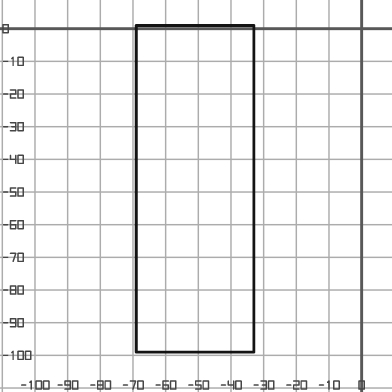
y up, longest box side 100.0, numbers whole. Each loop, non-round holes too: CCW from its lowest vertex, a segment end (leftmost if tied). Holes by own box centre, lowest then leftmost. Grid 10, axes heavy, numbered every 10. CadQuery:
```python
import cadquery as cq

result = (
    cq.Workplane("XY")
    .moveTo(-69.0, -99.0)
    .lineTo(-33.0, -99.0)
    .lineTo(-33.0, 1.0)
    .lineTo(-69.0, 1.0)
    .close()
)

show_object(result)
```